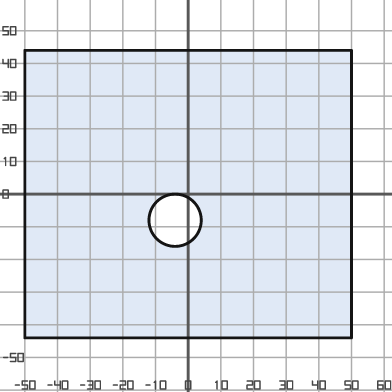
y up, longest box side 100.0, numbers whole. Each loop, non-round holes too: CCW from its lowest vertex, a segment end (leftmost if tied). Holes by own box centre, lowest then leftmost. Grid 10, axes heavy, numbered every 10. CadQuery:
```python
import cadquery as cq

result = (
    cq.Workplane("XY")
    .moveTo(-50.0, -44.0)
    .lineTo(50.0, -44.0)
    .lineTo(50.0, 44.0)
    .lineTo(-50.0, 44.0)
    .close()
    .moveTo(-4.0, -8.0)
    .circle(8.0)
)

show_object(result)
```